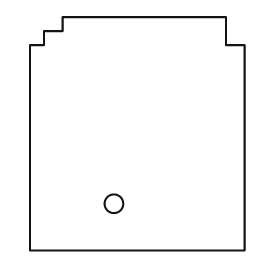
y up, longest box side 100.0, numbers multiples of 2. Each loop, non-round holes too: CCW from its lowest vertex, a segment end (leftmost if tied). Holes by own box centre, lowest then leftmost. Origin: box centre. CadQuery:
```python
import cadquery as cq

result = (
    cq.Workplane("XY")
    .moveTo(-46.0, -50.0)
    .lineTo(46.0, -50.0)
    .lineTo(46.0, 38.0)
    .lineTo(38.0, 38.0)
    .lineTo(38.0, 50.0)
    .lineTo(-32.0, 50.0)
    .lineTo(-32.0, 44.0)
    .lineTo(-40.0, 44.0)
    .lineTo(-40.0, 38.0)
    .lineTo(-46.0, 38.0)
    .close()
    .moveTo(-10.0, -30.0)
    .circle(4.0)
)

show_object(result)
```